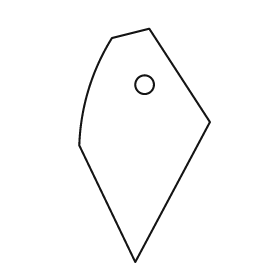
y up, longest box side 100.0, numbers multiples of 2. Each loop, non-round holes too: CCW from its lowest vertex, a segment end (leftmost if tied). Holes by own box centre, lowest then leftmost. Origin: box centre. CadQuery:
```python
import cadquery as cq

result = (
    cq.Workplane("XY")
    .moveTo(-4.0, -50.0)
    .lineTo(28.0, 10.0)
    .lineTo(2.0, 50.0)
    .lineTo(-14.0, 46.0)
    .threePointArc((-24.0, 24.0), (-28.0, 0.0))
    .close()
    .moveTo(0.0, 26.0)
    .circle(4.0)
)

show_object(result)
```